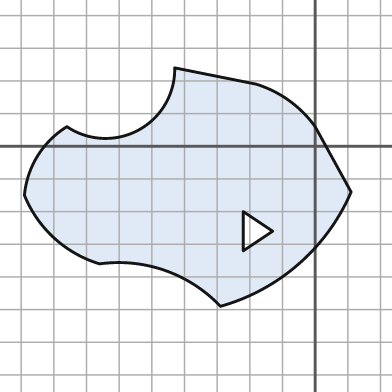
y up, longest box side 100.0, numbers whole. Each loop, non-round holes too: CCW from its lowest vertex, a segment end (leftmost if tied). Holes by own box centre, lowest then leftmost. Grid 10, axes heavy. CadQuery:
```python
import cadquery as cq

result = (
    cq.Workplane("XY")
    .moveTo(-29.0, -49.0)
    .threePointArc((-5.0, -36.0), (11.0, -14.0))
    .lineTo(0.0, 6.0)
    .threePointArc((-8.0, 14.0), (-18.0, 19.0))
    .lineTo(-43.0, 24.0)
    .threePointArc((-54.0, 5.0), (-76.0, 6.0))
    .threePointArc((-85.0, -3.0), (-89.0, -15.0))
    .threePointArc((-80.0, -28.0), (-66.0, -36.0))
    .threePointArc((-46.0, -38.0), (-29.0, -49.0))
    .close()
    .moveTo(-22.0, -32.0)
    .lineTo(-13.0, -26.0)
    .lineTo(-22.0, -20.0)
    .close()
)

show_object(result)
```